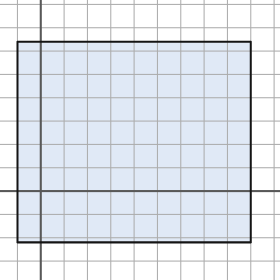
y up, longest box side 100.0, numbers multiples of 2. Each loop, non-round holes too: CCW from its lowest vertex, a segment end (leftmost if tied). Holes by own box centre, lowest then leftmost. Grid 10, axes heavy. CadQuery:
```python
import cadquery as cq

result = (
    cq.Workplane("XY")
    .moveTo(-10.0, -22.0)
    .lineTo(90.0, -22.0)
    .lineTo(90.0, 64.0)
    .lineTo(-10.0, 64.0)
    .close()
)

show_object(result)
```